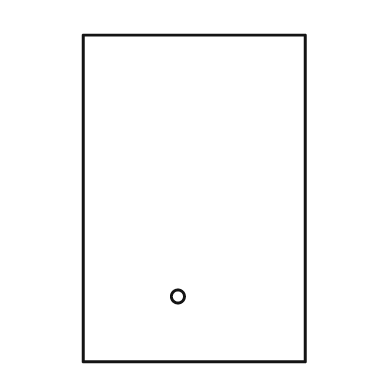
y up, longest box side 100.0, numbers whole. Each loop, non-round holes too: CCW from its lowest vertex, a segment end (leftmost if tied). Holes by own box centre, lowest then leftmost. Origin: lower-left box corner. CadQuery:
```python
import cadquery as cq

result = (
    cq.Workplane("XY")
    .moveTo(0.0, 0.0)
    .lineTo(68.0, 0.0)
    .lineTo(68.0, 100.0)
    .lineTo(0.0, 100.0)
    .close()
    .moveTo(29.0, 20.0)
    .circle(2.0)
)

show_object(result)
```